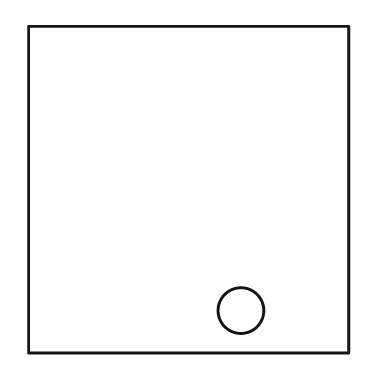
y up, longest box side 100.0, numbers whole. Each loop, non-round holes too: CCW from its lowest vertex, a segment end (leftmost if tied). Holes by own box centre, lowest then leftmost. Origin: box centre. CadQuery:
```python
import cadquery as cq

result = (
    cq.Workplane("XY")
    .moveTo(-49.0, -50.0)
    .lineTo(49.0, -50.0)
    .lineTo(49.0, 50.0)
    .lineTo(-49.0, 50.0)
    .close()
    .moveTo(16.0, -37.0)
    .circle(7.0)
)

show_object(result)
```